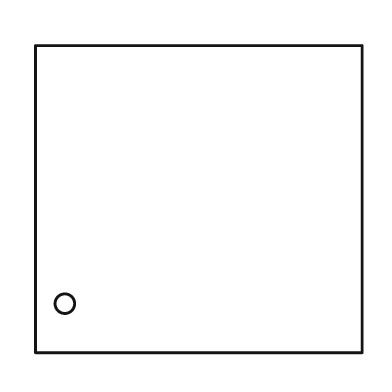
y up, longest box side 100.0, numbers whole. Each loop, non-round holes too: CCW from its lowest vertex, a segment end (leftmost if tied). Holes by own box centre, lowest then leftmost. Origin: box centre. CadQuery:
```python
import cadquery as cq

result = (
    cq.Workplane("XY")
    .moveTo(-50.0, -47.0)
    .lineTo(50.0, -47.0)
    .lineTo(50.0, 47.0)
    .lineTo(-50.0, 47.0)
    .close()
    .moveTo(-41.0, -32.0)
    .circle(3.0)
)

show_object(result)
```